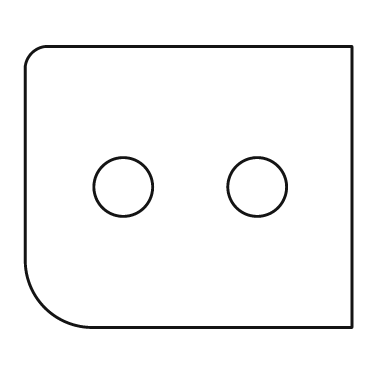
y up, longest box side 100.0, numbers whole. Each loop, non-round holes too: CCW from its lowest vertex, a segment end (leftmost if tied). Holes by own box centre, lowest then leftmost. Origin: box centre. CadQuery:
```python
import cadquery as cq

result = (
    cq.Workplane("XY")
    .moveTo(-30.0, -43.0)
    .lineTo(50.0, -43.0)
    .lineTo(50.0, 43.0)
    .lineTo(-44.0, 43.0)
    .threePointArc((-48.0, 41.0), (-50.0, 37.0))
    .lineTo(-50.0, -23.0)
    .threePointArc((-44.0, -37.0), (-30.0, -43.0))
    .close()
    .moveTo(-20.0, 0.0)
    .circle(9.0)
    .moveTo(21.0, 0.0)
    .circle(9.0)
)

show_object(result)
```